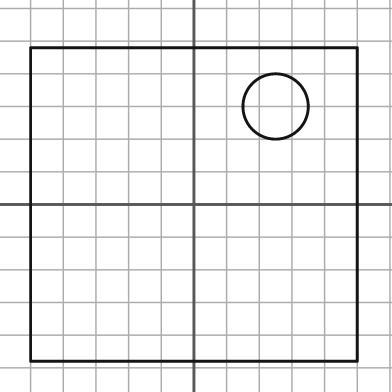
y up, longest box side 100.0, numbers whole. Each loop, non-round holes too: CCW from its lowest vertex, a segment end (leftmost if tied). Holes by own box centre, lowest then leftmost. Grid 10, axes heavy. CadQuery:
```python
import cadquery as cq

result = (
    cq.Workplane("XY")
    .moveTo(-50.0, -48.0)
    .lineTo(50.0, -48.0)
    .lineTo(50.0, 48.0)
    .lineTo(-50.0, 48.0)
    .close()
    .moveTo(25.0, 30.0)
    .circle(10.0)
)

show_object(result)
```